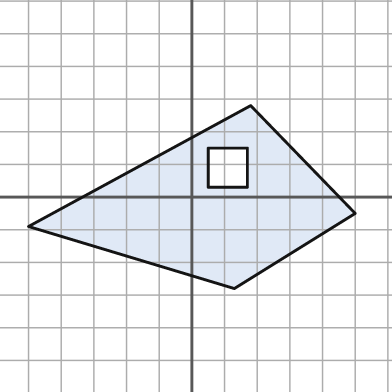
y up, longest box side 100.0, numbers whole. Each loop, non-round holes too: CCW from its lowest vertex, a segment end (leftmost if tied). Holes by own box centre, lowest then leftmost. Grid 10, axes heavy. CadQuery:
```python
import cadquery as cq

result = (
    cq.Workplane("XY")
    .moveTo(13.0, -28.0)
    .lineTo(50.0, -5.0)
    .lineTo(18.0, 28.0)
    .lineTo(-50.0, -9.0)
    .close()
    .moveTo(5.0, 3.0)
    .lineTo(17.0, 3.0)
    .lineTo(17.0, 15.0)
    .lineTo(5.0, 15.0)
    .close()
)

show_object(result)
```